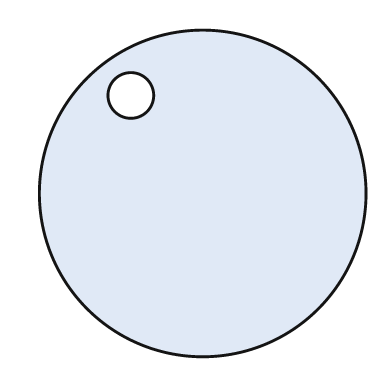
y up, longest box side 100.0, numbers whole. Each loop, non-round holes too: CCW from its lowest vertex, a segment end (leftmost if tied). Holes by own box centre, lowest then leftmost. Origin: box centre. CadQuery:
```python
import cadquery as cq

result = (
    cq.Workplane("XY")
    .moveTo(0.0, 0.0)
    .circle(50.0)
    .moveTo(-22.0, 30.0)
    .circle(7.0)
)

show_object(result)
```